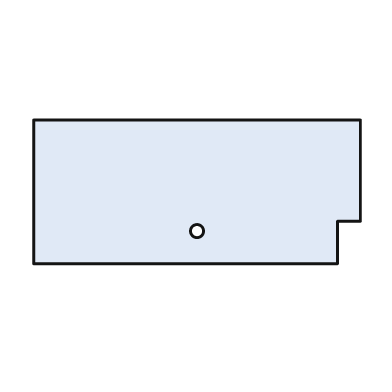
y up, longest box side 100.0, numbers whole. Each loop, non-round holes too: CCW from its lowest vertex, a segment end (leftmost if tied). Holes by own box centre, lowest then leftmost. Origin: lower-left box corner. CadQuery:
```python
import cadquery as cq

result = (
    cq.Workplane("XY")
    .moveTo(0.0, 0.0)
    .lineTo(93.0, 0.0)
    .lineTo(93.0, 13.0)
    .lineTo(100.0, 13.0)
    .lineTo(100.0, 44.0)
    .lineTo(0.0, 44.0)
    .close()
    .moveTo(50.0, 10.0)
    .circle(2.0)
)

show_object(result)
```